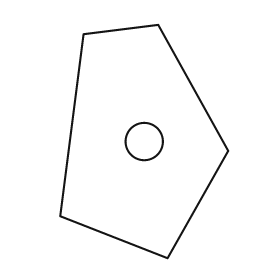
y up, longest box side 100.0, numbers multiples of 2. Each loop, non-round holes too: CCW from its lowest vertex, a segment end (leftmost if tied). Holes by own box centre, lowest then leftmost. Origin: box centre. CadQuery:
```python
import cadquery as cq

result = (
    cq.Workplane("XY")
    .moveTo(10.0, -50.0)
    .lineTo(36.0, -4.0)
    .lineTo(6.0, 50.0)
    .lineTo(-26.0, 46.0)
    .lineTo(-36.0, -32.0)
    .close()
    .moveTo(0.0, 0.0)
    .circle(8.0)
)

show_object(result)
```